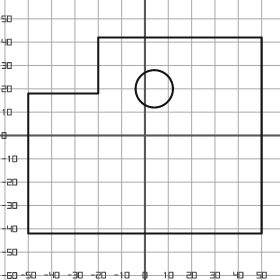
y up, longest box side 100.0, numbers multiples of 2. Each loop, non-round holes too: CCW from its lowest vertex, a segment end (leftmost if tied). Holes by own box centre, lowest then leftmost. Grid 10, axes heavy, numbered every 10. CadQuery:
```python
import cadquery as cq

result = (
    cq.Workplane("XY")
    .moveTo(-50.0, -42.0)
    .lineTo(50.0, -42.0)
    .lineTo(50.0, 42.0)
    .lineTo(-20.0, 42.0)
    .lineTo(-20.0, 18.0)
    .lineTo(-50.0, 18.0)
    .close()
    .moveTo(4.0, 20.0)
    .circle(8.0)
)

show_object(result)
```